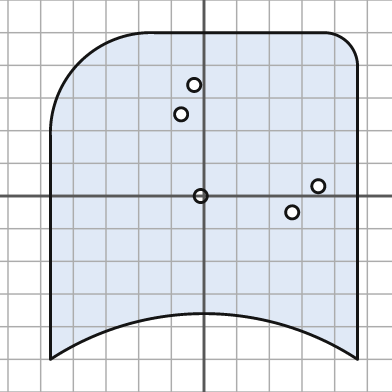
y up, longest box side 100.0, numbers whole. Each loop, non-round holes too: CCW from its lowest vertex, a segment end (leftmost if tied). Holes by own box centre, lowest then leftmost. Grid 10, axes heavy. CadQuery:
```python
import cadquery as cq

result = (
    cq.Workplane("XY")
    .moveTo(-47.0, -50.0)
    .threePointArc((0.0, -36.0), (47.0, -50.0))
    .lineTo(47.0, 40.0)
    .threePointArc((44.0, 47.0), (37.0, 50.0))
    .lineTo(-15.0, 50.0)
    .threePointArc((-38.0, 41.0), (-47.0, 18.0))
    .close()
    .moveTo(27.0, -5.0)
    .circle(2.0)
    .moveTo(-1.0, 0.0)
    .circle(2.0)
    .moveTo(35.0, 3.0)
    .circle(2.0)
    .moveTo(-7.0, 25.0)
    .circle(2.0)
    .moveTo(-3.0, 34.0)
    .circle(2.0)
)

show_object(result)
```